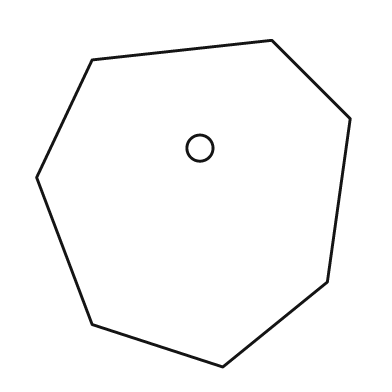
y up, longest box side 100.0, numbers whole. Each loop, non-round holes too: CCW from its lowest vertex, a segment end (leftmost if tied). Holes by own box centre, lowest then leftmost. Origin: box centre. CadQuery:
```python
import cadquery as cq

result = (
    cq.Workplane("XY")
    .moveTo(9.0, -50.0)
    .lineTo(41.0, -24.0)
    .lineTo(48.0, 26.0)
    .lineTo(24.0, 50.0)
    .lineTo(-31.0, 44.0)
    .lineTo(-48.0, 8.0)
    .lineTo(-31.0, -37.0)
    .close()
    .moveTo(2.0, 17.0)
    .circle(4.0)
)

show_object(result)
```